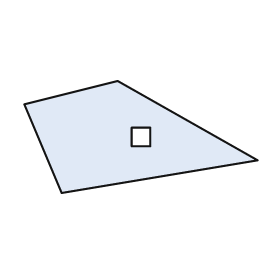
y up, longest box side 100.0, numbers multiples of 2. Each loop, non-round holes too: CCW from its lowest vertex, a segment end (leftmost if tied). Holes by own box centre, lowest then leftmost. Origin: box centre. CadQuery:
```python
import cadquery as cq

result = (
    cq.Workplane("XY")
    .moveTo(-34.0, -24.0)
    .lineTo(50.0, -10.0)
    .lineTo(-10.0, 24.0)
    .lineTo(-50.0, 14.0)
    .close()
    .moveTo(-4.0, -4.0)
    .lineTo(4.0, -4.0)
    .lineTo(4.0, 4.0)
    .lineTo(-4.0, 4.0)
    .close()
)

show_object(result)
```